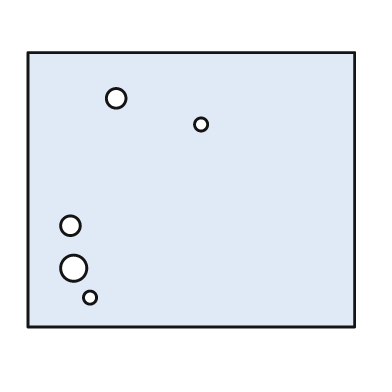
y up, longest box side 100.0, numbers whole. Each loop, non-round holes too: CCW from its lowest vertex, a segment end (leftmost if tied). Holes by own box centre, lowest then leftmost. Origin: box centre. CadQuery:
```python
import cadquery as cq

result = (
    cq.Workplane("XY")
    .moveTo(-50.0, -42.0)
    .lineTo(50.0, -42.0)
    .lineTo(50.0, 42.0)
    .lineTo(-50.0, 42.0)
    .close()
    .moveTo(-31.0, -33.0)
    .circle(2.0)
    .moveTo(-36.0, -24.0)
    .circle(4.0)
    .moveTo(-37.0, -11.0)
    .circle(3.0)
    .moveTo(3.0, 20.0)
    .circle(2.0)
    .moveTo(-23.0, 28.0)
    .circle(3.0)
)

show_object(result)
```